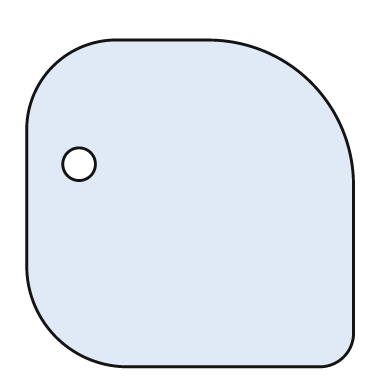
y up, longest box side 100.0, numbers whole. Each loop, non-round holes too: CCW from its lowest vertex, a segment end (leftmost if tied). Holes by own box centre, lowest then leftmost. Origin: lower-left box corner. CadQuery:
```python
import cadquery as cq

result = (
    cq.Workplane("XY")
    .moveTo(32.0, 0.0)
    .lineTo(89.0, 0.0)
    .threePointArc((97.0, 3.0), (100.0, 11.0))
    .lineTo(100.0, 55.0)
    .threePointArc((87.0, 87.0), (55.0, 100.0))
    .lineTo(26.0, 100.0)
    .threePointArc((8.0, 92.0), (0.0, 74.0))
    .lineTo(0.0, 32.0)
    .threePointArc((9.0, 9.0), (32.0, 0.0))
    .close()
    .moveTo(16.0, 62.0)
    .circle(5.0)
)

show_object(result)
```